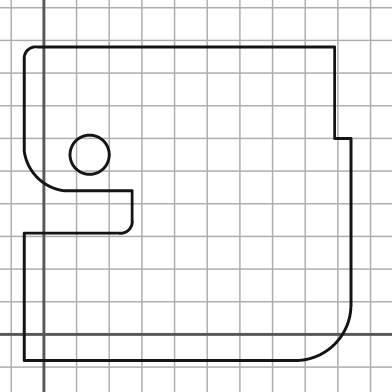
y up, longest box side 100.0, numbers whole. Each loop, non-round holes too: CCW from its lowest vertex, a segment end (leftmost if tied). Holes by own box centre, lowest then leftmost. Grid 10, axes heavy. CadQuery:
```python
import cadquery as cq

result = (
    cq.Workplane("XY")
    .moveTo(-6.0, -8.0)
    .lineTo(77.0, -8.0)
    .threePointArc((89.0, -3.0), (94.0, 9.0))
    .lineTo(94.0, 60.0)
    .lineTo(89.0, 60.0)
    .lineTo(89.0, 88.0)
    .lineTo(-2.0, 88.0)
    .threePointArc((-5.0, 87.0), (-6.0, 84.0))
    .lineTo(-6.0, 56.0)
    .threePointArc((-2.0, 48.0), (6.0, 44.0))
    .lineTo(27.0, 44.0)
    .lineTo(27.0, 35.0)
    .threePointArc((26.0, 32.0), (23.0, 31.0))
    .lineTo(-6.0, 31.0)
    .close()
    .moveTo(14.0, 55.0)
    .circle(6.0)
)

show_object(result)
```